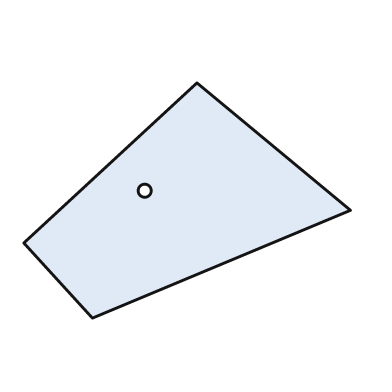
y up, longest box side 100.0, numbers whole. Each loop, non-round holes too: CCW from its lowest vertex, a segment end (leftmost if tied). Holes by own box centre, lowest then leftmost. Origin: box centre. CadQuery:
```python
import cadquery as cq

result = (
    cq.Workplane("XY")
    .moveTo(-29.0, -36.0)
    .lineTo(50.0, -3.0)
    .lineTo(3.0, 36.0)
    .lineTo(-50.0, -13.0)
    .close()
    .moveTo(-13.0, 3.0)
    .circle(2.0)
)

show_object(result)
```